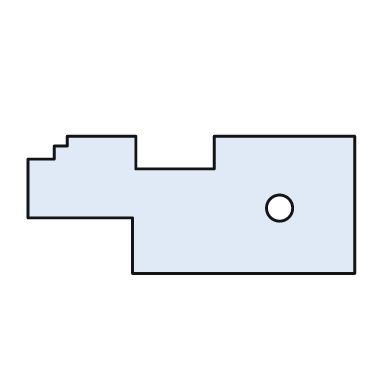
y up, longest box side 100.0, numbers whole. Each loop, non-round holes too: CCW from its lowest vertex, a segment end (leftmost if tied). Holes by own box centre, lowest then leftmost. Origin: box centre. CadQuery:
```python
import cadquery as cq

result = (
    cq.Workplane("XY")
    .moveTo(-18.0, -21.0)
    .lineTo(50.0, -21.0)
    .lineTo(50.0, 21.0)
    .lineTo(7.0, 21.0)
    .lineTo(7.0, 11.0)
    .lineTo(-17.0, 11.0)
    .lineTo(-17.0, 21.0)
    .lineTo(-38.0, 21.0)
    .lineTo(-38.0, 18.0)
    .lineTo(-42.0, 18.0)
    .lineTo(-42.0, 14.0)
    .lineTo(-50.0, 14.0)
    .lineTo(-50.0, -4.0)
    .lineTo(-18.0, -4.0)
    .close()
    .moveTo(27.0, -1.0)
    .circle(4.0)
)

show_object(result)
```